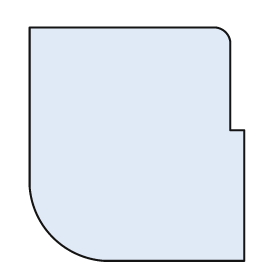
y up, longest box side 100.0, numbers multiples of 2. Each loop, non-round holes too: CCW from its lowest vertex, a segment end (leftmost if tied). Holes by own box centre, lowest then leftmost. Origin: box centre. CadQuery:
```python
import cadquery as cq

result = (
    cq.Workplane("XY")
    .moveTo(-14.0, -50.0)
    .lineTo(46.0, -50.0)
    .lineTo(46.0, 6.0)
    .lineTo(40.0, 6.0)
    .lineTo(40.0, 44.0)
    .threePointArc((38.0, 48.0), (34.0, 50.0))
    .lineTo(-46.0, 50.0)
    .lineTo(-46.0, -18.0)
    .threePointArc((-36.0, -40.0), (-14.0, -50.0))
    .close()
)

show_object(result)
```